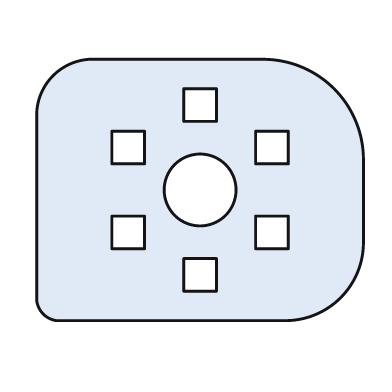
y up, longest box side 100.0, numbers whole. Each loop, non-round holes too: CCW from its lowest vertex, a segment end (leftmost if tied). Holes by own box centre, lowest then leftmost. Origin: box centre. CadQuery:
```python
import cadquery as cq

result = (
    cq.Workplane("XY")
    .moveTo(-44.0, -40.0)
    .lineTo(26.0, -40.0)
    .threePointArc((43.0, -33.0), (50.0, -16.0))
    .lineTo(50.0, 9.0)
    .threePointArc((41.0, 31.0), (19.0, 40.0))
    .lineTo(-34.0, 40.0)
    .threePointArc((-45.0, 35.0), (-50.0, 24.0))
    .lineTo(-50.0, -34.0)
    .threePointArc((-48.0, -38.0), (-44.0, -40.0))
    .close()
    .moveTo(-5.0, -31.0)
    .lineTo(5.0, -31.0)
    .lineTo(5.0, -21.0)
    .lineTo(-5.0, -21.0)
    .close()
    .moveTo(-27.0, -18.0)
    .lineTo(-17.0, -18.0)
    .lineTo(-17.0, -8.0)
    .lineTo(-27.0, -8.0)
    .close()
    .moveTo(17.0, -18.0)
    .lineTo(27.0, -18.0)
    .lineTo(27.0, -8.0)
    .lineTo(17.0, -8.0)
    .close()
    .moveTo(0.0, 0.0)
    .circle(11.0)
    .moveTo(-27.0, 8.0)
    .lineTo(-17.0, 8.0)
    .lineTo(-17.0, 18.0)
    .lineTo(-27.0, 18.0)
    .close()
    .moveTo(17.0, 8.0)
    .lineTo(27.0, 8.0)
    .lineTo(27.0, 18.0)
    .lineTo(17.0, 18.0)
    .close()
    .moveTo(-5.0, 21.0)
    .lineTo(5.0, 21.0)
    .lineTo(5.0, 31.0)
    .lineTo(-5.0, 31.0)
    .close()
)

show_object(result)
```